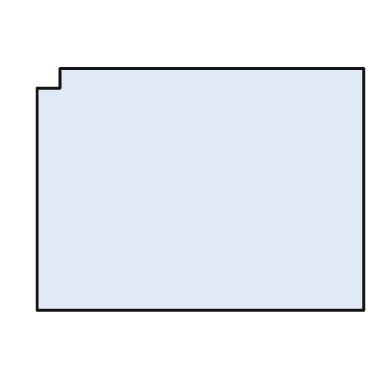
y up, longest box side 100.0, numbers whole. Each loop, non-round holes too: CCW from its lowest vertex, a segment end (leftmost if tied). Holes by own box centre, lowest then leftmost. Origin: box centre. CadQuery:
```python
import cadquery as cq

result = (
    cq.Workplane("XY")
    .moveTo(-50.0, -37.0)
    .lineTo(50.0, -37.0)
    .lineTo(50.0, 37.0)
    .lineTo(-43.0, 37.0)
    .lineTo(-43.0, 31.0)
    .lineTo(-50.0, 31.0)
    .close()
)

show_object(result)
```